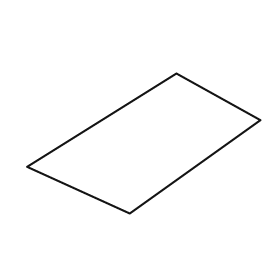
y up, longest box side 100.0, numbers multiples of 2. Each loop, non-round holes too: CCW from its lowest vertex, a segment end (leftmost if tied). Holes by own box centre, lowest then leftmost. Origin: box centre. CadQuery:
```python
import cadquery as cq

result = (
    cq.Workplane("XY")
    .moveTo(-6.0, -30.0)
    .lineTo(50.0, 10.0)
    .lineTo(14.0, 30.0)
    .lineTo(-50.0, -10.0)
    .close()
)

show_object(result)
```